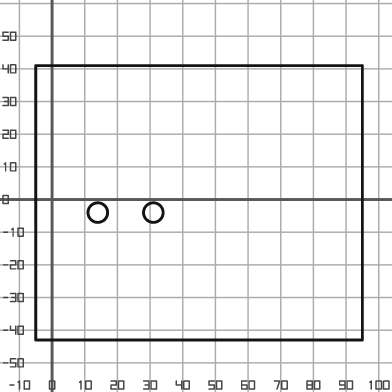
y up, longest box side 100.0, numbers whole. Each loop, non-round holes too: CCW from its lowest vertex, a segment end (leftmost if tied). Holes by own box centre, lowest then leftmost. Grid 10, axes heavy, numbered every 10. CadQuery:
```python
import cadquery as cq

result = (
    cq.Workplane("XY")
    .moveTo(-5.0, -43.0)
    .lineTo(95.0, -43.0)
    .lineTo(95.0, 41.0)
    .lineTo(-5.0, 41.0)
    .close()
    .moveTo(14.0, -4.0)
    .circle(3.0)
    .moveTo(31.0, -4.0)
    .circle(3.0)
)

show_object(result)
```